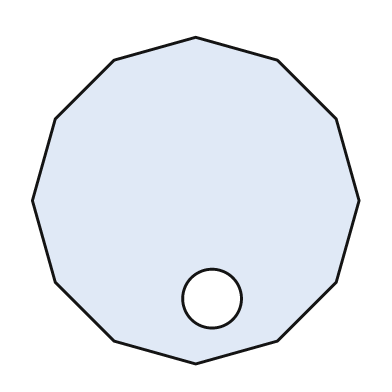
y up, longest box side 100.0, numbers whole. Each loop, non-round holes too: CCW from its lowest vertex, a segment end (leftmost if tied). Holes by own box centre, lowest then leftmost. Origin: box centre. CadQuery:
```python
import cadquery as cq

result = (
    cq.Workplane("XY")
    .moveTo(0.0, -50.0)
    .lineTo(25.0, -43.0)
    .lineTo(43.0, -25.0)
    .lineTo(50.0, 0.0)
    .lineTo(43.0, 25.0)
    .lineTo(25.0, 43.0)
    .lineTo(0.0, 50.0)
    .lineTo(-25.0, 43.0)
    .lineTo(-43.0, 25.0)
    .lineTo(-50.0, 0.0)
    .lineTo(-43.0, -25.0)
    .lineTo(-25.0, -43.0)
    .close()
    .moveTo(5.0, -30.0)
    .circle(9.0)
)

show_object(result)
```